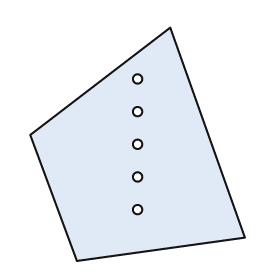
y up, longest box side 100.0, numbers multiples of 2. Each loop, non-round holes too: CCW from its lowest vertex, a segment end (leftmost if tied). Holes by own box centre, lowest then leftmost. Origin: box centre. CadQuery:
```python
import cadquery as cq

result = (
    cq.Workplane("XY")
    .moveTo(-26.0, -50.0)
    .lineTo(46.0, -40.0)
    .lineTo(14.0, 50.0)
    .lineTo(-46.0, 4.0)
    .close()
    .moveTo(0.0, -28.0)
    .circle(2.0)
    .moveTo(0.0, -14.0)
    .circle(2.0)
    .moveTo(0.0, 0.0)
    .circle(2.0)
    .moveTo(0.0, 14.0)
    .circle(2.0)
    .moveTo(0.0, 28.0)
    .circle(2.0)
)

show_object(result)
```